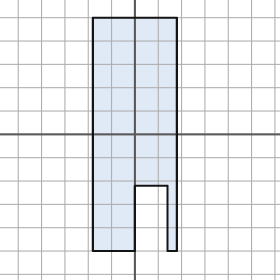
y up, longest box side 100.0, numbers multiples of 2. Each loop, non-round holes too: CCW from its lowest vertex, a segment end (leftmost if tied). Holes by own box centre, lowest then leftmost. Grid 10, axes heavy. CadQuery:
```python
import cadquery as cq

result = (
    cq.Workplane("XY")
    .moveTo(-18.0, -50.0)
    .lineTo(0.0, -50.0)
    .lineTo(0.0, -22.0)
    .lineTo(14.0, -22.0)
    .lineTo(14.0, -50.0)
    .lineTo(18.0, -50.0)
    .lineTo(18.0, 50.0)
    .lineTo(-18.0, 50.0)
    .close()
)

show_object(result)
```